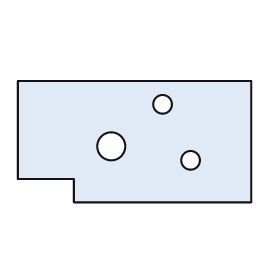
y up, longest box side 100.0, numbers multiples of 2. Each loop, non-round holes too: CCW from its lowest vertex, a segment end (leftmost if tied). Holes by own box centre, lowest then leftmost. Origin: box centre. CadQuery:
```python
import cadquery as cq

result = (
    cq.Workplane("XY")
    .moveTo(-26.0, -26.0)
    .lineTo(50.0, -26.0)
    .lineTo(50.0, 26.0)
    .lineTo(-50.0, 26.0)
    .lineTo(-50.0, -16.0)
    .lineTo(-26.0, -16.0)
    .close()
    .moveTo(24.0, -8.0)
    .circle(4.0)
    .moveTo(-10.0, -2.0)
    .circle(6.0)
    .moveTo(12.0, 16.0)
    .circle(4.0)
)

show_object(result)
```